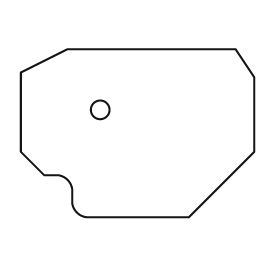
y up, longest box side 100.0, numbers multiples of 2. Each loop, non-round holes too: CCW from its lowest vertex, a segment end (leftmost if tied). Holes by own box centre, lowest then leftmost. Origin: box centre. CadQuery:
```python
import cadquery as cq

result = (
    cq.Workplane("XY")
    .moveTo(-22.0, -36.0)
    .lineTo(22.0, -36.0)
    .lineTo(50.0, -8.0)
    .lineTo(50.0, 24.0)
    .lineTo(42.0, 36.0)
    .lineTo(-30.0, 36.0)
    .lineTo(-50.0, 26.0)
    .lineTo(-50.0, -8.0)
    .lineTo(-40.0, -18.0)
    .lineTo(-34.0, -18.0)
    .threePointArc((-30.0, -20.0), (-28.0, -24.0))
    .lineTo(-28.0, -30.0)
    .threePointArc((-26.0, -34.0), (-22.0, -36.0))
    .close()
    .moveTo(-16.0, 10.0)
    .circle(4.0)
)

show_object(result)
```